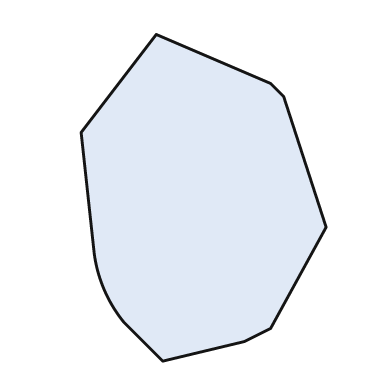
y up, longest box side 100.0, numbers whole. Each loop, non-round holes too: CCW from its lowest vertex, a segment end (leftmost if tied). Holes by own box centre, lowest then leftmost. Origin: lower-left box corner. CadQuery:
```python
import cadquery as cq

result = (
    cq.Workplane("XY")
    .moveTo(25.0, 0.0)
    .lineTo(50.0, 6.0)
    .lineTo(58.0, 10.0)
    .lineTo(75.0, 41.0)
    .lineTo(62.0, 81.0)
    .lineTo(58.0, 85.0)
    .lineTo(23.0, 100.0)
    .lineTo(0.0, 70.0)
    .lineTo(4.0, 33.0)
    .threePointArc((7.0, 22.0), (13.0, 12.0))
    .close()
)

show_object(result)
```